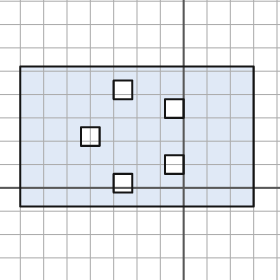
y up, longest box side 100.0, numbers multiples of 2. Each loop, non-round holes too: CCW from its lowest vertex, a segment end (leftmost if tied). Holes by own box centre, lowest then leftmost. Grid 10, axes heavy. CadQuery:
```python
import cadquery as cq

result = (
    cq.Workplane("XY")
    .moveTo(-70.0, -8.0)
    .lineTo(30.0, -8.0)
    .lineTo(30.0, 52.0)
    .lineTo(-70.0, 52.0)
    .close()
    .moveTo(-30.0, -2.0)
    .lineTo(-22.0, -2.0)
    .lineTo(-22.0, 6.0)
    .lineTo(-30.0, 6.0)
    .close()
    .moveTo(-8.0, 6.0)
    .lineTo(0.0, 6.0)
    .lineTo(0.0, 14.0)
    .lineTo(-8.0, 14.0)
    .close()
    .moveTo(-44.0, 18.0)
    .lineTo(-36.0, 18.0)
    .lineTo(-36.0, 26.0)
    .lineTo(-44.0, 26.0)
    .close()
    .moveTo(-8.0, 30.0)
    .lineTo(0.0, 30.0)
    .lineTo(0.0, 38.0)
    .lineTo(-8.0, 38.0)
    .close()
    .moveTo(-30.0, 38.0)
    .lineTo(-22.0, 38.0)
    .lineTo(-22.0, 46.0)
    .lineTo(-30.0, 46.0)
    .close()
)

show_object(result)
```